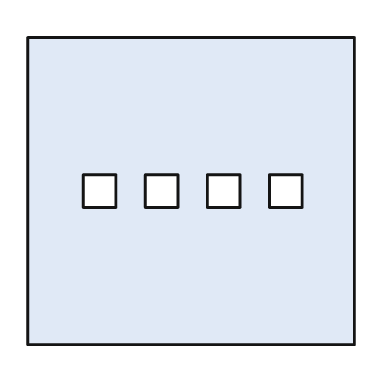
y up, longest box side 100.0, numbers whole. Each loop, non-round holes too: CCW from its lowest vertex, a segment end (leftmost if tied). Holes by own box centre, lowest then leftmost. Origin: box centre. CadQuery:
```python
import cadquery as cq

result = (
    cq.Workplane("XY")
    .moveTo(-50.0, -47.0)
    .lineTo(50.0, -47.0)
    .lineTo(50.0, 47.0)
    .lineTo(-50.0, 47.0)
    .close()
    .moveTo(-33.0, -5.0)
    .lineTo(-23.0, -5.0)
    .lineTo(-23.0, 5.0)
    .lineTo(-33.0, 5.0)
    .close()
    .moveTo(-14.0, -5.0)
    .lineTo(-4.0, -5.0)
    .lineTo(-4.0, 5.0)
    .lineTo(-14.0, 5.0)
    .close()
    .moveTo(5.0, -5.0)
    .lineTo(15.0, -5.0)
    .lineTo(15.0, 5.0)
    .lineTo(5.0, 5.0)
    .close()
    .moveTo(24.0, -5.0)
    .lineTo(34.0, -5.0)
    .lineTo(34.0, 5.0)
    .lineTo(24.0, 5.0)
    .close()
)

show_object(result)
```